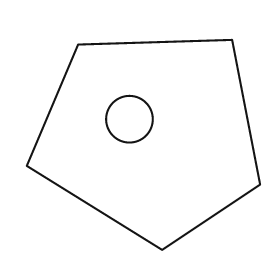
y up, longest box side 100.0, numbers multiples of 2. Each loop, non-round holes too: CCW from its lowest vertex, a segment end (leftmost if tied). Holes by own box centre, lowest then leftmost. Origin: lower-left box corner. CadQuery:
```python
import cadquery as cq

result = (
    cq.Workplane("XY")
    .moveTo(58.0, 0.0)
    .lineTo(100.0, 28.0)
    .lineTo(88.0, 90.0)
    .lineTo(22.0, 88.0)
    .lineTo(0.0, 36.0)
    .close()
    .moveTo(44.0, 56.0)
    .circle(10.0)
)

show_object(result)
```